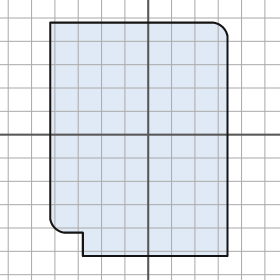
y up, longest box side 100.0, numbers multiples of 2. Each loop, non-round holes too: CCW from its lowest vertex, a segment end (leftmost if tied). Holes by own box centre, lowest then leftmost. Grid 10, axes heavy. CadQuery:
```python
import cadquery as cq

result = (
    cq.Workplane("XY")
    .moveTo(-28.0, -52.0)
    .lineTo(34.0, -52.0)
    .lineTo(34.0, 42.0)
    .threePointArc((32.0, 46.0), (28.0, 48.0))
    .lineTo(-42.0, 48.0)
    .lineTo(-42.0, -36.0)
    .threePointArc((-40.0, -40.0), (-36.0, -42.0))
    .lineTo(-28.0, -42.0)
    .close()
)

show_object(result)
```